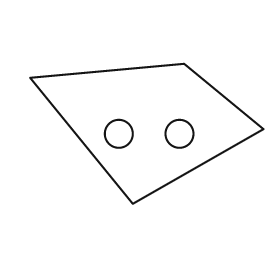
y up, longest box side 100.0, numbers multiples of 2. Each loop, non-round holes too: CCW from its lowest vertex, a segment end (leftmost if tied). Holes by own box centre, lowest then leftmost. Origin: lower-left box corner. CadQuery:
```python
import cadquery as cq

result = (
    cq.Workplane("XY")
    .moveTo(44.0, 0.0)
    .lineTo(100.0, 32.0)
    .lineTo(66.0, 60.0)
    .lineTo(0.0, 54.0)
    .close()
    .moveTo(38.0, 30.0)
    .circle(6.0)
    .moveTo(64.0, 30.0)
    .circle(6.0)
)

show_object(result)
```